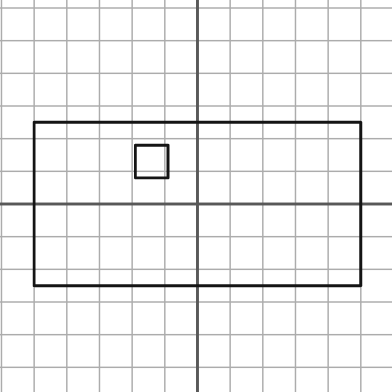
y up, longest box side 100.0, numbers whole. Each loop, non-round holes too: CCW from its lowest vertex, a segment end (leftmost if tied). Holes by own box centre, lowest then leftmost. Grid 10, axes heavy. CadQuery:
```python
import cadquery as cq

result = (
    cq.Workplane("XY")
    .moveTo(-50.0, -25.0)
    .lineTo(50.0, -25.0)
    .lineTo(50.0, 25.0)
    .lineTo(-50.0, 25.0)
    .close()
    .moveTo(-19.0, 8.0)
    .lineTo(-9.0, 8.0)
    .lineTo(-9.0, 18.0)
    .lineTo(-19.0, 18.0)
    .close()
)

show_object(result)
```